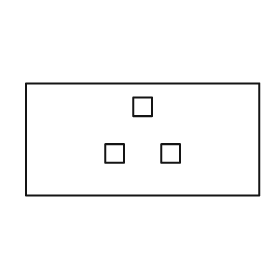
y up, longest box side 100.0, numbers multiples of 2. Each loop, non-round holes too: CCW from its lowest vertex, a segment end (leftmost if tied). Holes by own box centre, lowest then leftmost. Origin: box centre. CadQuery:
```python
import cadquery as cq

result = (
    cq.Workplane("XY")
    .moveTo(-50.0, -24.0)
    .lineTo(50.0, -24.0)
    .lineTo(50.0, 24.0)
    .lineTo(-50.0, 24.0)
    .close()
    .moveTo(-16.0, -10.0)
    .lineTo(-8.0, -10.0)
    .lineTo(-8.0, -2.0)
    .lineTo(-16.0, -2.0)
    .close()
    .moveTo(8.0, -10.0)
    .lineTo(16.0, -10.0)
    .lineTo(16.0, -2.0)
    .lineTo(8.0, -2.0)
    .close()
    .moveTo(-4.0, 10.0)
    .lineTo(4.0, 10.0)
    .lineTo(4.0, 18.0)
    .lineTo(-4.0, 18.0)
    .close()
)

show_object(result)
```